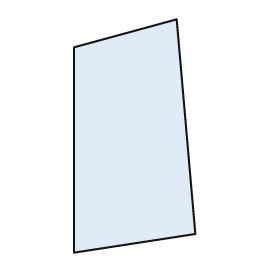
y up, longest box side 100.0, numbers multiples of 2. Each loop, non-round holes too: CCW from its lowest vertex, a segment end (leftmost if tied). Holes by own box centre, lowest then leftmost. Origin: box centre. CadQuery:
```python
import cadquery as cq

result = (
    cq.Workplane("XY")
    .moveTo(-26.0, -50.0)
    .lineTo(26.0, -42.0)
    .lineTo(18.0, 50.0)
    .lineTo(-26.0, 38.0)
    .close()
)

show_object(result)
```